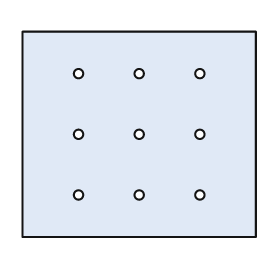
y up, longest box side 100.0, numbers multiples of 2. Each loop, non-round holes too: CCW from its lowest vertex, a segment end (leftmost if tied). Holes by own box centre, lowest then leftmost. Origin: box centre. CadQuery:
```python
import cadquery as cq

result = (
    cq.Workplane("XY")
    .moveTo(-50.0, -44.0)
    .lineTo(50.0, -44.0)
    .lineTo(50.0, 44.0)
    .lineTo(-50.0, 44.0)
    .close()
    .moveTo(-26.0, -26.0)
    .circle(2.0)
    .moveTo(0.0, -26.0)
    .circle(2.0)
    .moveTo(26.0, -26.0)
    .circle(2.0)
    .moveTo(-26.0, 0.0)
    .circle(2.0)
    .moveTo(0.0, 0.0)
    .circle(2.0)
    .moveTo(26.0, 0.0)
    .circle(2.0)
    .moveTo(-26.0, 26.0)
    .circle(2.0)
    .moveTo(0.0, 26.0)
    .circle(2.0)
    .moveTo(26.0, 26.0)
    .circle(2.0)
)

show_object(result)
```